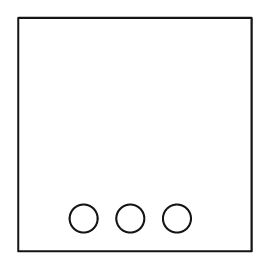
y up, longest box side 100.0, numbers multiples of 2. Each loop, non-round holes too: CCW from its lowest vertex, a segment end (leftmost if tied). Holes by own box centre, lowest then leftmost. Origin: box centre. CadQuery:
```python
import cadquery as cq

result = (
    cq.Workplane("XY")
    .moveTo(-50.0, -50.0)
    .lineTo(50.0, -50.0)
    .lineTo(50.0, 50.0)
    .lineTo(-50.0, 50.0)
    .close()
    .moveTo(-22.0, -36.0)
    .circle(6.0)
    .moveTo(-2.0, -36.0)
    .circle(6.0)
    .moveTo(18.0, -36.0)
    .circle(6.0)
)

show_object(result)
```